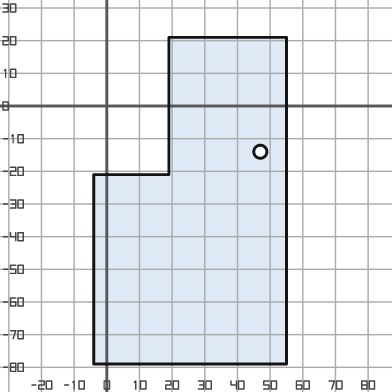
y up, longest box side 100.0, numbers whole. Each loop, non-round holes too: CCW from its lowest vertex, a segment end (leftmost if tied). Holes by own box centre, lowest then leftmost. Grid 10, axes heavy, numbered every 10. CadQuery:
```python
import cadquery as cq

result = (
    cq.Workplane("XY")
    .moveTo(-4.0, -79.0)
    .lineTo(55.0, -79.0)
    .lineTo(55.0, 21.0)
    .lineTo(19.0, 21.0)
    .lineTo(19.0, -21.0)
    .lineTo(-4.0, -21.0)
    .close()
    .moveTo(47.0, -14.0)
    .circle(2.0)
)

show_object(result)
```